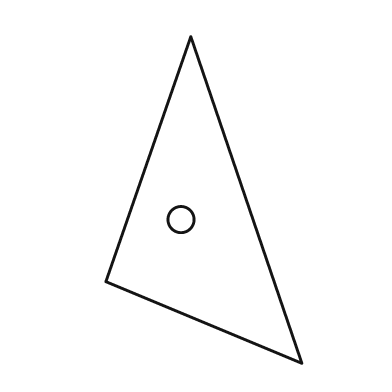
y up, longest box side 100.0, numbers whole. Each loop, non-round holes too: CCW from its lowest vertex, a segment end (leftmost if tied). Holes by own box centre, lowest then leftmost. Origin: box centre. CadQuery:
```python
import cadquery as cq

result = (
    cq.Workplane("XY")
    .moveTo(30.0, -50.0)
    .lineTo(-4.0, 50.0)
    .lineTo(-30.0, -25.0)
    .close()
    .moveTo(-7.0, -6.0)
    .circle(4.0)
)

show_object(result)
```